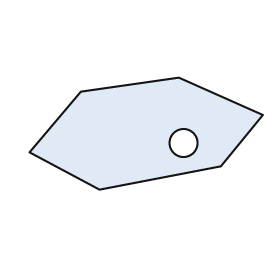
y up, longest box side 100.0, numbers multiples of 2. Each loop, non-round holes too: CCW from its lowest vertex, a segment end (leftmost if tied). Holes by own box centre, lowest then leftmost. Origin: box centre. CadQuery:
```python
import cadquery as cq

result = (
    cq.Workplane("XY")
    .moveTo(-20.0, -24.0)
    .lineTo(32.0, -14.0)
    .lineTo(50.0, 8.0)
    .lineTo(14.0, 24.0)
    .lineTo(-28.0, 18.0)
    .lineTo(-50.0, -8.0)
    .close()
    .moveTo(16.0, -4.0)
    .circle(6.0)
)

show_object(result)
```